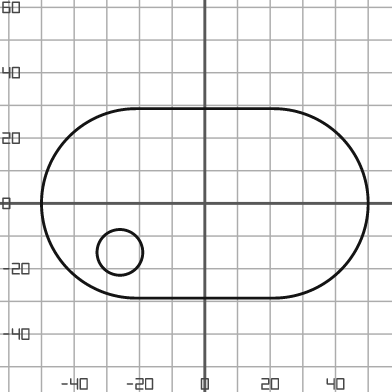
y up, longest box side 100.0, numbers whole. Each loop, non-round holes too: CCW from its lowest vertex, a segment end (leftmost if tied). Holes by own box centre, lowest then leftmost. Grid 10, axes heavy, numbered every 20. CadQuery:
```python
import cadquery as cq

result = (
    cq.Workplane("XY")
    .moveTo(-21.0, -29.0)
    .lineTo(21.0, -29.0)
    .threePointArc((50.0, 0.0), (21.0, 29.0))
    .lineTo(-21.0, 29.0)
    .threePointArc((-50.0, 0.0), (-21.0, -29.0))
    .close()
    .moveTo(-26.0, -15.0)
    .circle(7.0)
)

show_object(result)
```